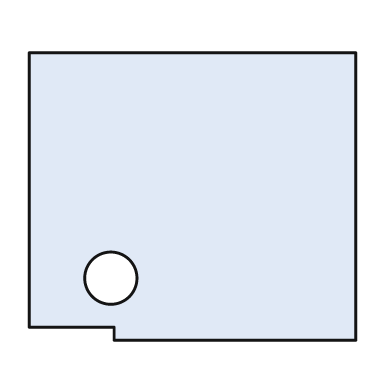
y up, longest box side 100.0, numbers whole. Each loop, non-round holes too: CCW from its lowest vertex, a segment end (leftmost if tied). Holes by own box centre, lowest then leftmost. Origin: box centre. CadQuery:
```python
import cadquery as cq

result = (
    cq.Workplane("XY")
    .moveTo(-24.0, -44.0)
    .lineTo(50.0, -44.0)
    .lineTo(50.0, 44.0)
    .lineTo(-50.0, 44.0)
    .lineTo(-50.0, -40.0)
    .lineTo(-24.0, -40.0)
    .close()
    .moveTo(-25.0, -25.0)
    .circle(8.0)
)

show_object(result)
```